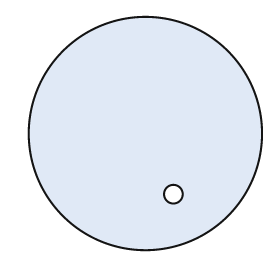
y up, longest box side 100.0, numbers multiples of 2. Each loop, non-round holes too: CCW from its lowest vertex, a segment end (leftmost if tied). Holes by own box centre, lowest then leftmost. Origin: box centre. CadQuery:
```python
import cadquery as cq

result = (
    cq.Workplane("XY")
    .moveTo(0.0, 0.0)
    .circle(50.0)
    .moveTo(12.0, -26.0)
    .circle(4.0)
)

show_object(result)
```